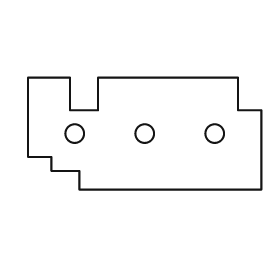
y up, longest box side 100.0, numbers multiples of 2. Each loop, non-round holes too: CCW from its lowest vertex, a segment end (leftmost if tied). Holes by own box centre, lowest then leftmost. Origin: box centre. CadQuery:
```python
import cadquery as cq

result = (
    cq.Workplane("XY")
    .moveTo(-28.0, -24.0)
    .lineTo(50.0, -24.0)
    .lineTo(50.0, 10.0)
    .lineTo(40.0, 10.0)
    .lineTo(40.0, 24.0)
    .lineTo(-20.0, 24.0)
    .lineTo(-20.0, 10.0)
    .lineTo(-32.0, 10.0)
    .lineTo(-32.0, 24.0)
    .lineTo(-50.0, 24.0)
    .lineTo(-50.0, -10.0)
    .lineTo(-40.0, -10.0)
    .lineTo(-40.0, -16.0)
    .lineTo(-28.0, -16.0)
    .close()
    .moveTo(-30.0, 0.0)
    .circle(4.0)
    .moveTo(0.0, 0.0)
    .circle(4.0)
    .moveTo(30.0, 0.0)
    .circle(4.0)
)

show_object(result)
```